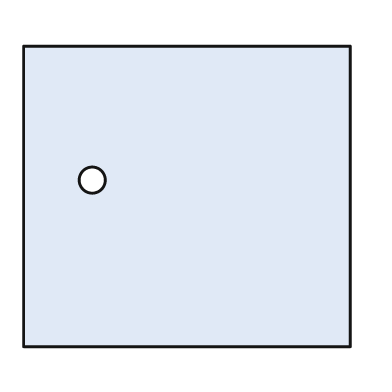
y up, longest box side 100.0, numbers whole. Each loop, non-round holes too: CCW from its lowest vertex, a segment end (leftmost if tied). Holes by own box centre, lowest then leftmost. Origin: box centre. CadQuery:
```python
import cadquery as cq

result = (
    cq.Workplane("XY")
    .moveTo(-50.0, -46.0)
    .lineTo(50.0, -46.0)
    .lineTo(50.0, 46.0)
    .lineTo(-50.0, 46.0)
    .close()
    .moveTo(-29.0, 5.0)
    .circle(4.0)
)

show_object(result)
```